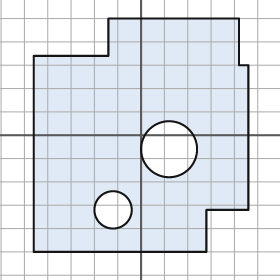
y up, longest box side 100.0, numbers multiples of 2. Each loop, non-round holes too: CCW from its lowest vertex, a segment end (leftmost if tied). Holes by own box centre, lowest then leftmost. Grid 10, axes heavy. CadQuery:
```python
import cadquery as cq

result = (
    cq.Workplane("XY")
    .moveTo(-46.0, -50.0)
    .lineTo(28.0, -50.0)
    .lineTo(28.0, -32.0)
    .lineTo(46.0, -32.0)
    .lineTo(46.0, 30.0)
    .lineTo(42.0, 30.0)
    .lineTo(42.0, 50.0)
    .lineTo(-14.0, 50.0)
    .lineTo(-14.0, 34.0)
    .lineTo(-46.0, 34.0)
    .close()
    .moveTo(-12.0, -32.0)
    .circle(8.0)
    .moveTo(12.0, -6.0)
    .circle(12.0)
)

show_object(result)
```